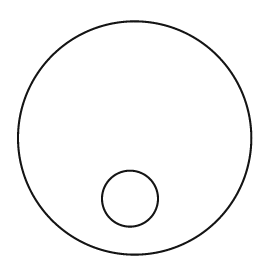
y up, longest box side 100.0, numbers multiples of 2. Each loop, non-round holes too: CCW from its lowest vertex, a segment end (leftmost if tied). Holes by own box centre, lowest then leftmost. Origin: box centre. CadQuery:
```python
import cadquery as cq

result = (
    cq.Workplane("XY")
    .moveTo(0.0, 0.0)
    .circle(50.0)
    .moveTo(-2.0, -26.0)
    .circle(12.0)
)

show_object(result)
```